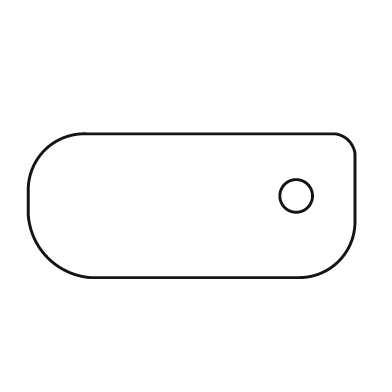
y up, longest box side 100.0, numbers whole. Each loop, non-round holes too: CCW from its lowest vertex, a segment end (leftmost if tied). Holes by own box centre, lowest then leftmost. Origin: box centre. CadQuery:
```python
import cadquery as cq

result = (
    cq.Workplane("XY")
    .moveTo(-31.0, -22.0)
    .lineTo(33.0, -22.0)
    .threePointArc((45.0, -17.0), (50.0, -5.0))
    .lineTo(50.0, 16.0)
    .threePointArc((48.0, 20.0), (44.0, 22.0))
    .lineTo(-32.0, 22.0)
    .threePointArc((-45.0, 17.0), (-50.0, 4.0))
    .lineTo(-50.0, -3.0)
    .threePointArc((-44.0, -16.0), (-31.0, -22.0))
    .close()
    .moveTo(32.0, 3.0)
    .circle(5.0)
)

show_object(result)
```